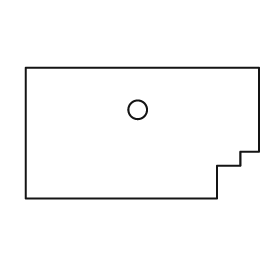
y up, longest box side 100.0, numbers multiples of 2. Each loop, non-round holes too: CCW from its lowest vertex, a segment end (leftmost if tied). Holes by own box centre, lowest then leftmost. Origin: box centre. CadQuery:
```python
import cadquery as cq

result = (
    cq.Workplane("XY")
    .moveTo(-50.0, -28.0)
    .lineTo(32.0, -28.0)
    .lineTo(32.0, -14.0)
    .lineTo(42.0, -14.0)
    .lineTo(42.0, -8.0)
    .lineTo(50.0, -8.0)
    .lineTo(50.0, 28.0)
    .lineTo(-50.0, 28.0)
    .close()
    .moveTo(-2.0, 10.0)
    .circle(4.0)
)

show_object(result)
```